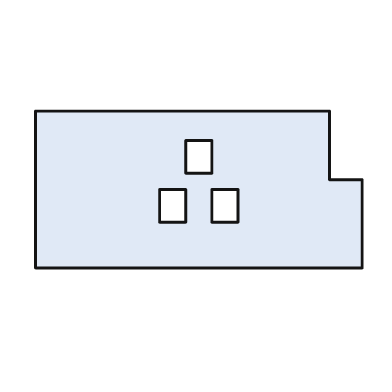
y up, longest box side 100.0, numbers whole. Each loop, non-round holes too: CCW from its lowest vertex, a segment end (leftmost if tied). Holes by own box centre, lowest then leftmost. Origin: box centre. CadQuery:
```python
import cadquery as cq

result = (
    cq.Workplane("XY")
    .moveTo(-50.0, -24.0)
    .lineTo(50.0, -24.0)
    .lineTo(50.0, 3.0)
    .lineTo(40.0, 3.0)
    .lineTo(40.0, 24.0)
    .lineTo(-50.0, 24.0)
    .close()
    .moveTo(-12.0, -10.0)
    .lineTo(-4.0, -10.0)
    .lineTo(-4.0, 0.0)
    .lineTo(-12.0, 0.0)
    .close()
    .moveTo(4.0, -10.0)
    .lineTo(12.0, -10.0)
    .lineTo(12.0, 0.0)
    .lineTo(4.0, 0.0)
    .close()
    .moveTo(-4.0, 5.0)
    .lineTo(4.0, 5.0)
    .lineTo(4.0, 15.0)
    .lineTo(-4.0, 15.0)
    .close()
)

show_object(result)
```